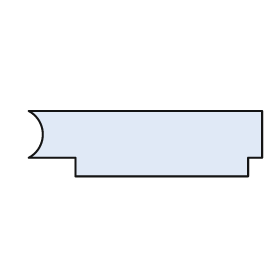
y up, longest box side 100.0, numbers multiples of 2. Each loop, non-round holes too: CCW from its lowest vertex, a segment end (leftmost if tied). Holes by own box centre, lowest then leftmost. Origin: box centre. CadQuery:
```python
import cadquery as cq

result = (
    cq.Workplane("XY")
    .moveTo(-30.0, -14.0)
    .lineTo(44.0, -14.0)
    .lineTo(44.0, -6.0)
    .lineTo(50.0, -6.0)
    .lineTo(50.0, 14.0)
    .lineTo(-50.0, 14.0)
    .threePointArc((-44.0, 4.0), (-50.0, -6.0))
    .lineTo(-30.0, -6.0)
    .close()
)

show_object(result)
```